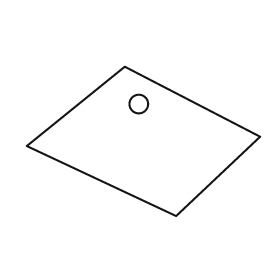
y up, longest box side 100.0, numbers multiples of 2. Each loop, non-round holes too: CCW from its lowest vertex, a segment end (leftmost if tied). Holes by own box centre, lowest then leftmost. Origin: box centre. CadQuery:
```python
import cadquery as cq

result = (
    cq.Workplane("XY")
    .moveTo(14.0, -32.0)
    .lineTo(50.0, 2.0)
    .lineTo(-8.0, 32.0)
    .lineTo(-50.0, -2.0)
    .close()
    .moveTo(-2.0, 16.0)
    .circle(4.0)
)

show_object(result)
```